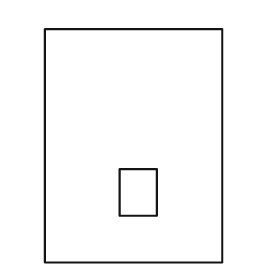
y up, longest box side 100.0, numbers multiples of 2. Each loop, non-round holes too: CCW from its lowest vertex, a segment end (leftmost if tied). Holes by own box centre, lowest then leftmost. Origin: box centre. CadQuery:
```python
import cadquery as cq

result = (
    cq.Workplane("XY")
    .moveTo(-38.0, -50.0)
    .lineTo(38.0, -50.0)
    .lineTo(38.0, 50.0)
    .lineTo(-38.0, 50.0)
    .close()
    .moveTo(-6.0, -30.0)
    .lineTo(10.0, -30.0)
    .lineTo(10.0, -10.0)
    .lineTo(-6.0, -10.0)
    .close()
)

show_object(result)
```